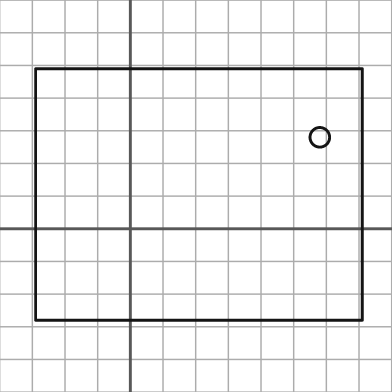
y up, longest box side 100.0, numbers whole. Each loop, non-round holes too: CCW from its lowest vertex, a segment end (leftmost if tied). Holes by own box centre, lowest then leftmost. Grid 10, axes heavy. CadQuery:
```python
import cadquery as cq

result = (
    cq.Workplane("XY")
    .moveTo(-29.0, -28.0)
    .lineTo(71.0, -28.0)
    .lineTo(71.0, 49.0)
    .lineTo(-29.0, 49.0)
    .close()
    .moveTo(58.0, 28.0)
    .circle(3.0)
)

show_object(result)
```